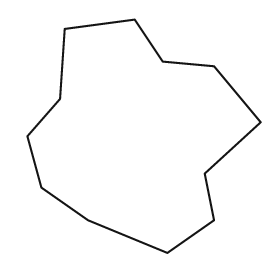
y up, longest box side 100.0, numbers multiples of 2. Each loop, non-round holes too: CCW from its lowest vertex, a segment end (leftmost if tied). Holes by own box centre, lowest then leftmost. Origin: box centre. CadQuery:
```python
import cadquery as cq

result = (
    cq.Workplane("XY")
    .moveTo(10.0, -50.0)
    .lineTo(30.0, -36.0)
    .lineTo(26.0, -16.0)
    .lineTo(50.0, 6.0)
    .lineTo(30.0, 30.0)
    .lineTo(8.0, 32.0)
    .lineTo(-4.0, 50.0)
    .lineTo(-34.0, 46.0)
    .lineTo(-36.0, 16.0)
    .lineTo(-50.0, 0.0)
    .lineTo(-44.0, -22.0)
    .lineTo(-24.0, -36.0)
    .close()
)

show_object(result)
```